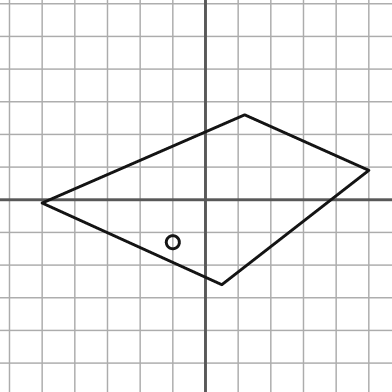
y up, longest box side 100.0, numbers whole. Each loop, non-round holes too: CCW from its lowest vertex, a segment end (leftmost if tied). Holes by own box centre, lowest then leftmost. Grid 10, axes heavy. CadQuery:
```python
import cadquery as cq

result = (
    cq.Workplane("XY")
    .moveTo(5.0, -26.0)
    .lineTo(50.0, 9.0)
    .lineTo(12.0, 26.0)
    .lineTo(-50.0, -1.0)
    .close()
    .moveTo(-10.0, -13.0)
    .circle(2.0)
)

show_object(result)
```